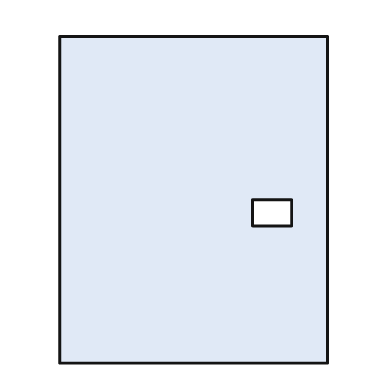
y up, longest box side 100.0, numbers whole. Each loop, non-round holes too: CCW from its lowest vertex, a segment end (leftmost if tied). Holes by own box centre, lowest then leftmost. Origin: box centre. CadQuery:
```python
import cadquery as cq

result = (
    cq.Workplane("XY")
    .moveTo(-41.0, -50.0)
    .lineTo(41.0, -50.0)
    .lineTo(41.0, 50.0)
    .lineTo(-41.0, 50.0)
    .close()
    .moveTo(18.0, -8.0)
    .lineTo(30.0, -8.0)
    .lineTo(30.0, 0.0)
    .lineTo(18.0, 0.0)
    .close()
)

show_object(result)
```